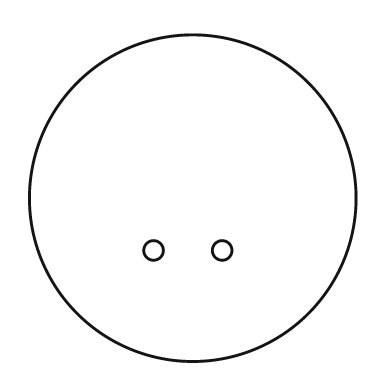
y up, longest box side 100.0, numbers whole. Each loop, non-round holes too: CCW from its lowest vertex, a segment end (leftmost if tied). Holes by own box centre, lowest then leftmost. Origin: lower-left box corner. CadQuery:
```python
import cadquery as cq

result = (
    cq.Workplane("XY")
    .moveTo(50.0, 50.0)
    .circle(50.0)
    .moveTo(38.0, 34.0)
    .circle(3.0)
    .moveTo(59.0, 34.0)
    .circle(3.0)
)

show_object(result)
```